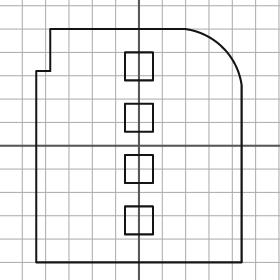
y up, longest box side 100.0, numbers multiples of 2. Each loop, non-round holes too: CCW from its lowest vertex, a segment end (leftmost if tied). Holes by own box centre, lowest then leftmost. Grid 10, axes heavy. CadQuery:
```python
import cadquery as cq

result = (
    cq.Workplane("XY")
    .moveTo(-44.0, -50.0)
    .lineTo(44.0, -50.0)
    .lineTo(44.0, 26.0)
    .threePointArc((36.0, 42.0), (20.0, 50.0))
    .lineTo(-38.0, 50.0)
    .lineTo(-38.0, 32.0)
    .lineTo(-44.0, 32.0)
    .close()
    .moveTo(-6.0, -38.0)
    .lineTo(6.0, -38.0)
    .lineTo(6.0, -26.0)
    .lineTo(-6.0, -26.0)
    .close()
    .moveTo(-6.0, -16.0)
    .lineTo(6.0, -16.0)
    .lineTo(6.0, -4.0)
    .lineTo(-6.0, -4.0)
    .close()
    .moveTo(-6.0, 6.0)
    .lineTo(6.0, 6.0)
    .lineTo(6.0, 18.0)
    .lineTo(-6.0, 18.0)
    .close()
    .moveTo(-6.0, 28.0)
    .lineTo(6.0, 28.0)
    .lineTo(6.0, 40.0)
    .lineTo(-6.0, 40.0)
    .close()
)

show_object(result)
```